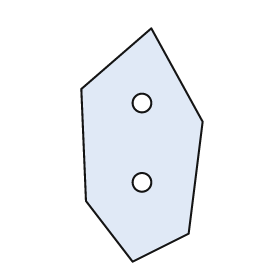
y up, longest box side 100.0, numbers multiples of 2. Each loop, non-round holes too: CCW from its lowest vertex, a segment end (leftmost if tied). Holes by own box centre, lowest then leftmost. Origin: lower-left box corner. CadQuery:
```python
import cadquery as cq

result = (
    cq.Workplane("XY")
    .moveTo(22.0, 0.0)
    .lineTo(46.0, 12.0)
    .lineTo(52.0, 60.0)
    .lineTo(30.0, 100.0)
    .lineTo(0.0, 74.0)
    .lineTo(2.0, 26.0)
    .close()
    .moveTo(26.0, 34.0)
    .circle(4.0)
    .moveTo(26.0, 68.0)
    .circle(4.0)
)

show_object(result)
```